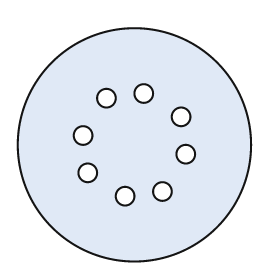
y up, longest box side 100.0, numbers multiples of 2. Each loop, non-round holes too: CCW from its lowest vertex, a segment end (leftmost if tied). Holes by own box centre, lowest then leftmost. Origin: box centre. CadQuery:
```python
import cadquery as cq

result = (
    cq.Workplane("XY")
    .moveTo(0.0, 0.0)
    .circle(50.0)
    .moveTo(-4.0, -22.0)
    .circle(4.0)
    .moveTo(12.0, -20.0)
    .circle(4.0)
    .moveTo(-20.0, -12.0)
    .circle(4.0)
    .moveTo(22.0, -4.0)
    .circle(4.0)
    .moveTo(-22.0, 4.0)
    .circle(4.0)
    .moveTo(20.0, 12.0)
    .circle(4.0)
    .moveTo(-12.0, 20.0)
    .circle(4.0)
    .moveTo(4.0, 22.0)
    .circle(4.0)
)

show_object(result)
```